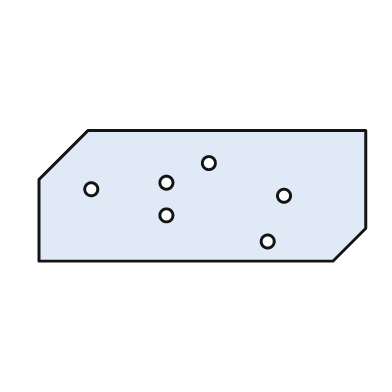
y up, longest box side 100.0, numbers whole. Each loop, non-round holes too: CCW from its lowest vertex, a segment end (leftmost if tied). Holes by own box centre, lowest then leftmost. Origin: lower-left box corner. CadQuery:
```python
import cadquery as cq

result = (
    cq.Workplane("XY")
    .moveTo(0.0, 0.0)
    .lineTo(90.0, 0.0)
    .lineTo(100.0, 10.0)
    .lineTo(100.0, 40.0)
    .lineTo(15.0, 40.0)
    .lineTo(0.0, 25.0)
    .close()
    .moveTo(70.0, 6.0)
    .circle(2.0)
    .moveTo(39.0, 14.0)
    .circle(2.0)
    .moveTo(75.0, 20.0)
    .circle(2.0)
    .moveTo(16.0, 22.0)
    .circle(2.0)
    .moveTo(39.0, 24.0)
    .circle(2.0)
    .moveTo(52.0, 30.0)
    .circle(2.0)
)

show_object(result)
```